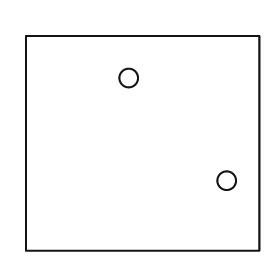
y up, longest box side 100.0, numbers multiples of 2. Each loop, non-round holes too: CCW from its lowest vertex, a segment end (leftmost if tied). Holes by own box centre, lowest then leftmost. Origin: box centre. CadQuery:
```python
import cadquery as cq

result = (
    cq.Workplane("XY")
    .moveTo(-50.0, -46.0)
    .lineTo(50.0, -46.0)
    .lineTo(50.0, 46.0)
    .lineTo(-50.0, 46.0)
    .close()
    .moveTo(36.0, -16.0)
    .circle(4.0)
    .moveTo(-6.0, 28.0)
    .circle(4.0)
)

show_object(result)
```